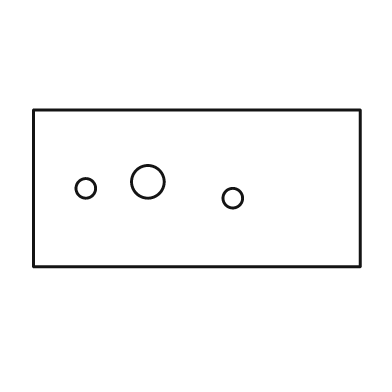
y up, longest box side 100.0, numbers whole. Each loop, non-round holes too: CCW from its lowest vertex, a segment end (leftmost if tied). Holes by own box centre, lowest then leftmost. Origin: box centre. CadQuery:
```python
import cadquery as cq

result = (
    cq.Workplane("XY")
    .moveTo(-50.0, -24.0)
    .lineTo(50.0, -24.0)
    .lineTo(50.0, 24.0)
    .lineTo(-50.0, 24.0)
    .close()
    .moveTo(11.0, -3.0)
    .circle(3.0)
    .moveTo(-34.0, 0.0)
    .circle(3.0)
    .moveTo(-15.0, 2.0)
    .circle(5.0)
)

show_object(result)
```